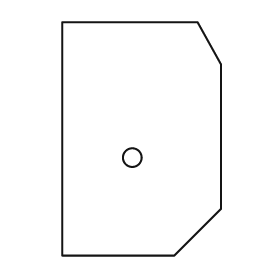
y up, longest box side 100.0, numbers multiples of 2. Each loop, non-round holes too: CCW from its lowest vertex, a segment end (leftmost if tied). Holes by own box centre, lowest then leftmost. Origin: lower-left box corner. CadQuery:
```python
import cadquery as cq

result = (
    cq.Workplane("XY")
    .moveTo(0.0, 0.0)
    .lineTo(48.0, 0.0)
    .lineTo(68.0, 20.0)
    .lineTo(68.0, 82.0)
    .lineTo(58.0, 100.0)
    .lineTo(0.0, 100.0)
    .close()
    .moveTo(30.0, 42.0)
    .circle(4.0)
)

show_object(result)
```